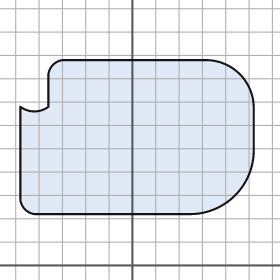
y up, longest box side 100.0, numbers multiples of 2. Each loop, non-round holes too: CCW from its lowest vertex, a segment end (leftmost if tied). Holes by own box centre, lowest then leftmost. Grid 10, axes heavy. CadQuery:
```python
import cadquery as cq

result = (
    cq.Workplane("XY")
    .moveTo(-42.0, 22.0)
    .lineTo(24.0, 22.0)
    .threePointArc((44.0, 30.0), (52.0, 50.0))
    .lineTo(52.0, 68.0)
    .threePointArc((46.0, 82.0), (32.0, 88.0))
    .lineTo(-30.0, 88.0)
    .threePointArc((-34.0, 86.0), (-36.0, 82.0))
    .lineTo(-36.0, 68.0)
    .threePointArc((-42.0, 66.0), (-48.0, 68.0))
    .lineTo(-48.0, 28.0)
    .threePointArc((-46.0, 24.0), (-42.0, 22.0))
    .close()
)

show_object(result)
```